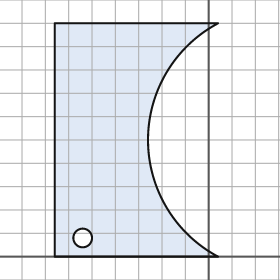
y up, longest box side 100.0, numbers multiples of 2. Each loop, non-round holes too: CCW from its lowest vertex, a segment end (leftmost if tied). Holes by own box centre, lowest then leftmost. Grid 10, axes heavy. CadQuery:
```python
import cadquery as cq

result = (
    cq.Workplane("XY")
    .moveTo(-66.0, 0.0)
    .lineTo(4.0, 0.0)
    .threePointArc((-26.0, 50.0), (4.0, 100.0))
    .lineTo(-66.0, 100.0)
    .close()
    .moveTo(-54.0, 8.0)
    .circle(4.0)
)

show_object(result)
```